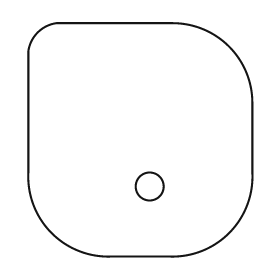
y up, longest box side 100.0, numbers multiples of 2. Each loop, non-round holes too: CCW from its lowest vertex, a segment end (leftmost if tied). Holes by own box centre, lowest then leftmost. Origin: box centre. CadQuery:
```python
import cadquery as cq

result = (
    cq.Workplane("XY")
    .moveTo(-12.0, -50.0)
    .lineTo(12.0, -50.0)
    .threePointArc((38.0, -40.0), (48.0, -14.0))
    .lineTo(48.0, 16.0)
    .threePointArc((38.0, 40.0), (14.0, 50.0))
    .lineTo(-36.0, 50.0)
    .threePointArc((-44.0, 46.0), (-48.0, 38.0))
    .lineTo(-48.0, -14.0)
    .threePointArc((-38.0, -40.0), (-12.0, -50.0))
    .close()
    .moveTo(4.0, -20.0)
    .circle(6.0)
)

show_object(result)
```